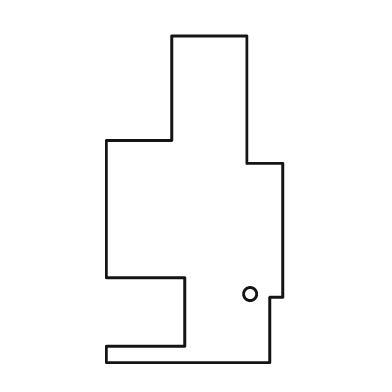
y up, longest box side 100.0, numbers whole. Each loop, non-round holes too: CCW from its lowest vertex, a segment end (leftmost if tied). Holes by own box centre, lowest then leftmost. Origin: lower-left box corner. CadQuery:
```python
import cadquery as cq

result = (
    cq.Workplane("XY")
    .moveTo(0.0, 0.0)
    .lineTo(50.0, 0.0)
    .lineTo(50.0, 20.0)
    .lineTo(54.0, 20.0)
    .lineTo(54.0, 61.0)
    .lineTo(43.0, 61.0)
    .lineTo(43.0, 100.0)
    .lineTo(20.0, 100.0)
    .lineTo(20.0, 68.0)
    .lineTo(0.0, 68.0)
    .lineTo(0.0, 26.0)
    .lineTo(24.0, 26.0)
    .lineTo(24.0, 5.0)
    .lineTo(0.0, 5.0)
    .close()
    .moveTo(44.0, 21.0)
    .circle(2.0)
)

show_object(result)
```